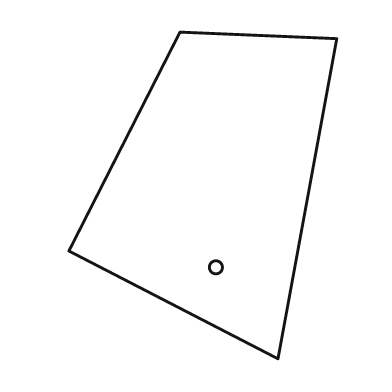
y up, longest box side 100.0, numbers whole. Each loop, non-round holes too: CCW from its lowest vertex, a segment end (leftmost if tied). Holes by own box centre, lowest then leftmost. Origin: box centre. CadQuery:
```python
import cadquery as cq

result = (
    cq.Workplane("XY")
    .moveTo(23.0, -50.0)
    .lineTo(41.0, 48.0)
    .lineTo(-7.0, 50.0)
    .lineTo(-41.0, -17.0)
    .close()
    .moveTo(4.0, -22.0)
    .circle(2.0)
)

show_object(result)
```